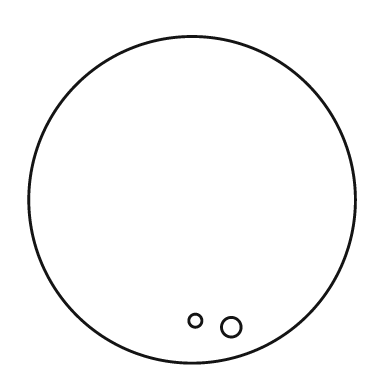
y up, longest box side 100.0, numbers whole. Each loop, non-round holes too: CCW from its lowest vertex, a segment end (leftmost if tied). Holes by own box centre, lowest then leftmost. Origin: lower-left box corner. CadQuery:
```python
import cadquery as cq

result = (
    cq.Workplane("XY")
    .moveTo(50.0, 50.0)
    .circle(50.0)
    .moveTo(62.0, 11.0)
    .circle(3.0)
    .moveTo(51.0, 13.0)
    .circle(2.0)
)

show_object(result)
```